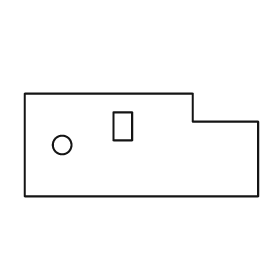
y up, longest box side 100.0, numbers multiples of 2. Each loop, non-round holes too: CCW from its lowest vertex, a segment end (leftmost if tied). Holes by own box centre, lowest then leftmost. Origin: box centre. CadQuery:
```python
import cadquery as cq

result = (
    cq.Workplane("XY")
    .moveTo(-50.0, -22.0)
    .lineTo(50.0, -22.0)
    .lineTo(50.0, 10.0)
    .lineTo(22.0, 10.0)
    .lineTo(22.0, 22.0)
    .lineTo(-50.0, 22.0)
    .close()
    .moveTo(-34.0, 0.0)
    .circle(4.0)
    .moveTo(-12.0, 2.0)
    .lineTo(-4.0, 2.0)
    .lineTo(-4.0, 14.0)
    .lineTo(-12.0, 14.0)
    .close()
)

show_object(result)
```